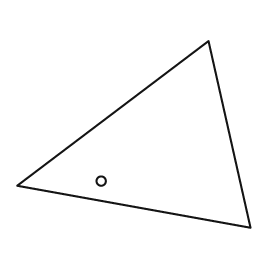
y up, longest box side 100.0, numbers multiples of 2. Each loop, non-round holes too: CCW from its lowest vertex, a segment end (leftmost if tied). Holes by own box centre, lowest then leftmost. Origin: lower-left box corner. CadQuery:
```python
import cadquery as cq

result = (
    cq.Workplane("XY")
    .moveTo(100.0, 0.0)
    .lineTo(82.0, 80.0)
    .lineTo(0.0, 18.0)
    .close()
    .moveTo(36.0, 20.0)
    .circle(2.0)
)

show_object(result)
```